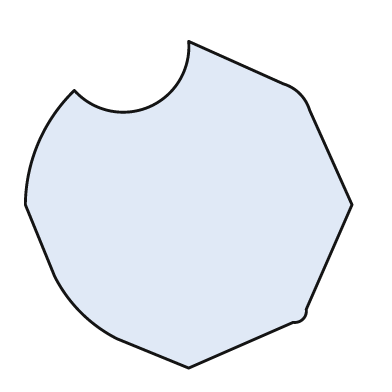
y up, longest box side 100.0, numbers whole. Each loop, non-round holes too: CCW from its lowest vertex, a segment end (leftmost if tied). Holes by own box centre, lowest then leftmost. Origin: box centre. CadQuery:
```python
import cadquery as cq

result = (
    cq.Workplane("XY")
    .moveTo(0.0, -50.0)
    .lineTo(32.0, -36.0)
    .threePointArc((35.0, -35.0), (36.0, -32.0))
    .lineTo(50.0, 0.0)
    .lineTo(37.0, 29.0)
    .threePointArc((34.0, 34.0), (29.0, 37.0))
    .lineTo(0.0, 50.0)
    .threePointArc((-12.0, 30.0), (-35.0, 35.0))
    .threePointArc((-46.0, 19.0), (-50.0, 0.0))
    .lineTo(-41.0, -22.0)
    .threePointArc((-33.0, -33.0), (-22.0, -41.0))
    .close()
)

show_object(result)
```